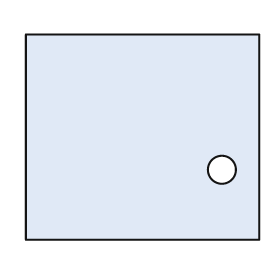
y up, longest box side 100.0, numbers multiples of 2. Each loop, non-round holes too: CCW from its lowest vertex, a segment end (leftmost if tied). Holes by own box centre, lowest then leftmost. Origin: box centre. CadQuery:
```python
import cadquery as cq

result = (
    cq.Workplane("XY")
    .moveTo(-50.0, -44.0)
    .lineTo(50.0, -44.0)
    .lineTo(50.0, 44.0)
    .lineTo(-50.0, 44.0)
    .close()
    .moveTo(34.0, -14.0)
    .circle(6.0)
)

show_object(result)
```